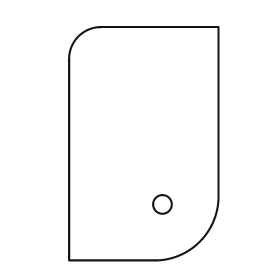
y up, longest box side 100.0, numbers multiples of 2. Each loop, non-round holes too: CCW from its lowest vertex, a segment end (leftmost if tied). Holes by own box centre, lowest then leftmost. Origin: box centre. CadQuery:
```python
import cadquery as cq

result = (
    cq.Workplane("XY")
    .moveTo(-32.0, -50.0)
    .lineTo(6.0, -50.0)
    .threePointArc((24.0, -42.0), (32.0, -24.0))
    .lineTo(32.0, 50.0)
    .lineTo(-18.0, 50.0)
    .threePointArc((-28.0, 46.0), (-32.0, 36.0))
    .close()
    .moveTo(8.0, -26.0)
    .circle(4.0)
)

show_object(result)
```